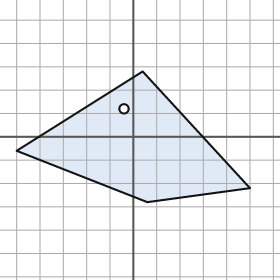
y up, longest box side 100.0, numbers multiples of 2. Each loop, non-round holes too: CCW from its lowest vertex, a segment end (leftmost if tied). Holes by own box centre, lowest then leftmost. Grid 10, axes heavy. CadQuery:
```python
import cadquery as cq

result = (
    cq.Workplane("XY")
    .moveTo(6.0, -28.0)
    .lineTo(50.0, -22.0)
    .lineTo(4.0, 28.0)
    .lineTo(-50.0, -6.0)
    .close()
    .moveTo(-4.0, 12.0)
    .circle(2.0)
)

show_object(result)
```